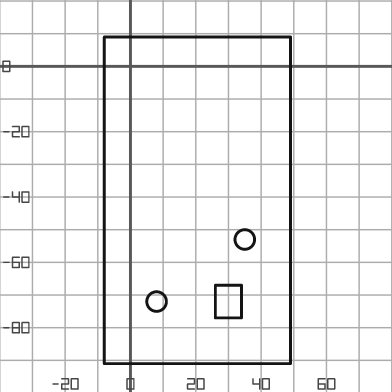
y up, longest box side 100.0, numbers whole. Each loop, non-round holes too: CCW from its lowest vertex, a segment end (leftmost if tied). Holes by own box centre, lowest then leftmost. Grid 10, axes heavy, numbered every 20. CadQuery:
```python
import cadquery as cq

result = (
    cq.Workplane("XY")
    .moveTo(-8.0, -91.0)
    .lineTo(49.0, -91.0)
    .lineTo(49.0, 9.0)
    .lineTo(-8.0, 9.0)
    .close()
    .moveTo(8.0, -72.0)
    .circle(3.0)
    .moveTo(26.0, -77.0)
    .lineTo(34.0, -77.0)
    .lineTo(34.0, -67.0)
    .lineTo(26.0, -67.0)
    .close()
    .moveTo(35.0, -53.0)
    .circle(3.0)
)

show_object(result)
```